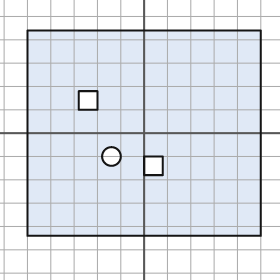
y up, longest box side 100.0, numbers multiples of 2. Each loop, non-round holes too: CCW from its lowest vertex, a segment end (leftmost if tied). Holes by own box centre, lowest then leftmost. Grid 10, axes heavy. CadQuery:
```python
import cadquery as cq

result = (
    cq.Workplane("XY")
    .moveTo(-50.0, -44.0)
    .lineTo(50.0, -44.0)
    .lineTo(50.0, 44.0)
    .lineTo(-50.0, 44.0)
    .close()
    .moveTo(0.0, -18.0)
    .lineTo(8.0, -18.0)
    .lineTo(8.0, -10.0)
    .lineTo(0.0, -10.0)
    .close()
    .moveTo(-14.0, -10.0)
    .circle(4.0)
    .moveTo(-28.0, 10.0)
    .lineTo(-20.0, 10.0)
    .lineTo(-20.0, 18.0)
    .lineTo(-28.0, 18.0)
    .close()
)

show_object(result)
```